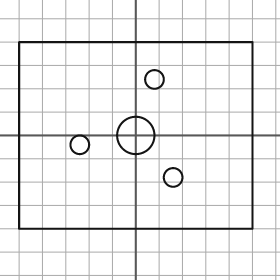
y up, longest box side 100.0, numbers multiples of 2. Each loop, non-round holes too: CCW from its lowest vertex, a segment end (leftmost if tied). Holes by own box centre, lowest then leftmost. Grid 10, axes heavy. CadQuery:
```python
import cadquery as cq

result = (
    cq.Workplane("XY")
    .moveTo(-50.0, -40.0)
    .lineTo(50.0, -40.0)
    .lineTo(50.0, 40.0)
    .lineTo(-50.0, 40.0)
    .close()
    .moveTo(16.0, -18.0)
    .circle(4.0)
    .moveTo(-24.0, -4.0)
    .circle(4.0)
    .moveTo(0.0, 0.0)
    .circle(8.0)
    .moveTo(8.0, 24.0)
    .circle(4.0)
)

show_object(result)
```